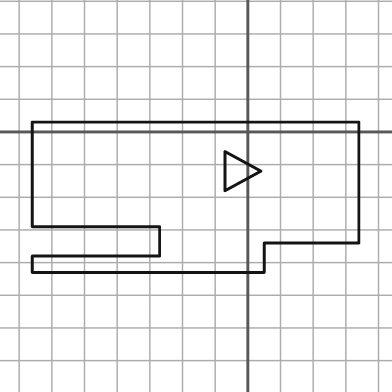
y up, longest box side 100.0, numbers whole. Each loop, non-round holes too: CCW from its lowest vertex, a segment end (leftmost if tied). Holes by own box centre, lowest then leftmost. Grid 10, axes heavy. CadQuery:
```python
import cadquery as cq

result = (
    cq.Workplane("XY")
    .moveTo(-66.0, -43.0)
    .lineTo(5.0, -43.0)
    .lineTo(5.0, -34.0)
    .lineTo(34.0, -34.0)
    .lineTo(34.0, 3.0)
    .lineTo(-66.0, 3.0)
    .lineTo(-66.0, -29.0)
    .lineTo(-27.0, -29.0)
    .lineTo(-27.0, -38.0)
    .lineTo(-66.0, -38.0)
    .close()
    .moveTo(-7.0, -18.0)
    .lineTo(4.0, -12.0)
    .lineTo(-7.0, -6.0)
    .close()
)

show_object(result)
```